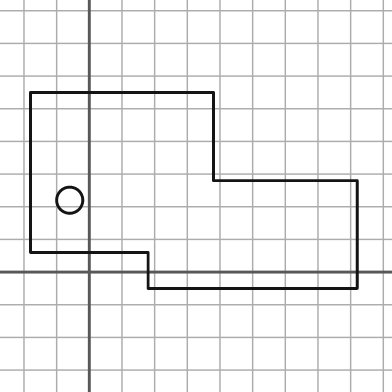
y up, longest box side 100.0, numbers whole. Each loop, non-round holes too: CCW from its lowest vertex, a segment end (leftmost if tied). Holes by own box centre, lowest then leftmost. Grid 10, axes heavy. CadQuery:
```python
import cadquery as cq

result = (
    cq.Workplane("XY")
    .moveTo(18.0, -5.0)
    .lineTo(82.0, -5.0)
    .lineTo(82.0, 28.0)
    .lineTo(38.0, 28.0)
    .lineTo(38.0, 55.0)
    .lineTo(-18.0, 55.0)
    .lineTo(-18.0, 6.0)
    .lineTo(18.0, 6.0)
    .close()
    .moveTo(-6.0, 22.0)
    .circle(4.0)
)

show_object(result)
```